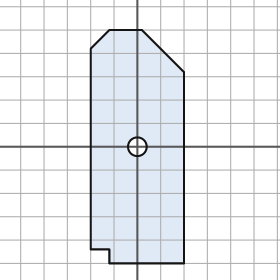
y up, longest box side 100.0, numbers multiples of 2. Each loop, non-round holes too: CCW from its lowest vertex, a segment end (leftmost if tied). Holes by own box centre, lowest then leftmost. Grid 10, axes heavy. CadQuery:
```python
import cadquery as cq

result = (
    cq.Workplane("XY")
    .moveTo(-12.0, -50.0)
    .lineTo(20.0, -50.0)
    .lineTo(20.0, 32.0)
    .lineTo(2.0, 50.0)
    .lineTo(-12.0, 50.0)
    .lineTo(-20.0, 42.0)
    .lineTo(-20.0, -44.0)
    .lineTo(-12.0, -44.0)
    .close()
    .moveTo(0.0, 0.0)
    .circle(4.0)
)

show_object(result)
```